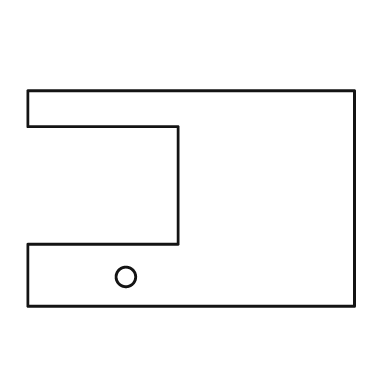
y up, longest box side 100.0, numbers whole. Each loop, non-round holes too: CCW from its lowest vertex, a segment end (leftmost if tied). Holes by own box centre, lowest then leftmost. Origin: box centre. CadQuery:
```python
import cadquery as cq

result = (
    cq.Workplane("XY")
    .moveTo(-50.0, -33.0)
    .lineTo(50.0, -33.0)
    .lineTo(50.0, 33.0)
    .lineTo(-50.0, 33.0)
    .lineTo(-50.0, 22.0)
    .lineTo(-4.0, 22.0)
    .lineTo(-4.0, -14.0)
    .lineTo(-50.0, -14.0)
    .close()
    .moveTo(-20.0, -24.0)
    .circle(3.0)
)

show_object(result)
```